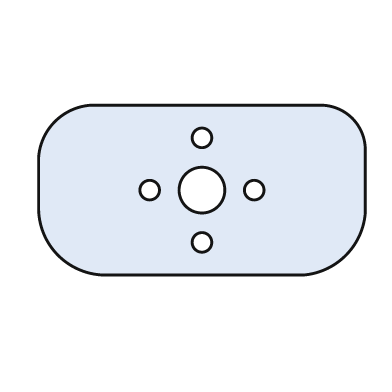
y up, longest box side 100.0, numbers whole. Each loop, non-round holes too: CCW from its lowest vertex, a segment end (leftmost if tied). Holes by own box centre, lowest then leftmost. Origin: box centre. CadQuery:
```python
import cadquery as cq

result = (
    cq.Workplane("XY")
    .moveTo(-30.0, -26.0)
    .lineTo(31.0, -26.0)
    .threePointArc((44.0, -20.0), (50.0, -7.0))
    .lineTo(50.0, 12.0)
    .threePointArc((46.0, 22.0), (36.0, 26.0))
    .lineTo(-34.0, 26.0)
    .threePointArc((-45.0, 21.0), (-50.0, 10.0))
    .lineTo(-50.0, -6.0)
    .threePointArc((-44.0, -20.0), (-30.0, -26.0))
    .close()
    .moveTo(0.0, -16.0)
    .circle(3.0)
    .moveTo(-16.0, 0.0)
    .circle(3.0)
    .moveTo(0.0, 0.0)
    .circle(7.0)
    .moveTo(16.0, 0.0)
    .circle(3.0)
    .moveTo(0.0, 16.0)
    .circle(3.0)
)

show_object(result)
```